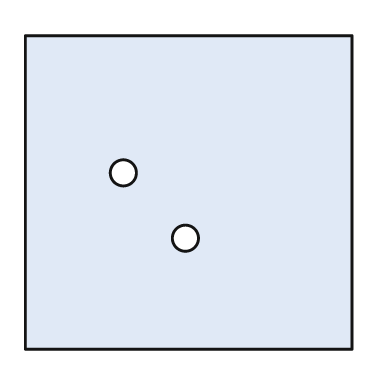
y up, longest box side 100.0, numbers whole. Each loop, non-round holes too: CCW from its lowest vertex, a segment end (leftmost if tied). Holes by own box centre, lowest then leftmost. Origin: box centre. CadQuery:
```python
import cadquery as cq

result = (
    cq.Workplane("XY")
    .moveTo(-50.0, -48.0)
    .lineTo(50.0, -48.0)
    .lineTo(50.0, 48.0)
    .lineTo(-50.0, 48.0)
    .close()
    .moveTo(-1.0, -14.0)
    .circle(4.0)
    .moveTo(-20.0, 6.0)
    .circle(4.0)
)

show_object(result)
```